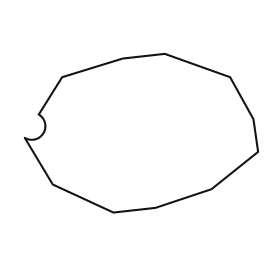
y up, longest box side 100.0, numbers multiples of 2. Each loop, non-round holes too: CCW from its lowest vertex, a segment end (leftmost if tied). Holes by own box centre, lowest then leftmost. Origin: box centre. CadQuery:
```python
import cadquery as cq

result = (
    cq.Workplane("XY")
    .moveTo(-12.0, -34.0)
    .lineTo(6.0, -32.0)
    .lineTo(30.0, -24.0)
    .lineTo(50.0, -8.0)
    .lineTo(48.0, 6.0)
    .lineTo(38.0, 24.0)
    .lineTo(10.0, 34.0)
    .lineTo(-8.0, 32.0)
    .lineTo(-34.0, 24.0)
    .lineTo(-44.0, 8.0)
    .threePointArc((-42.0, 0.0), (-50.0, -2.0))
    .lineTo(-38.0, -22.0)
    .close()
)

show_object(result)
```